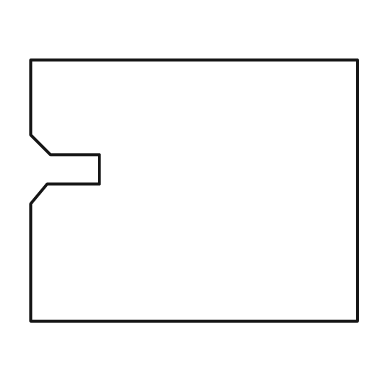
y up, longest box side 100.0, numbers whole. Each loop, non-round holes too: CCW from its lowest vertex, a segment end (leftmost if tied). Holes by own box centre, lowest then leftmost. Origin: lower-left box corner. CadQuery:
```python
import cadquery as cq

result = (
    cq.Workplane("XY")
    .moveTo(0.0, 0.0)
    .lineTo(100.0, 0.0)
    .lineTo(100.0, 80.0)
    .lineTo(0.0, 80.0)
    .lineTo(0.0, 57.0)
    .lineTo(6.0, 51.0)
    .lineTo(21.0, 51.0)
    .lineTo(21.0, 42.0)
    .lineTo(5.0, 42.0)
    .lineTo(0.0, 36.0)
    .close()
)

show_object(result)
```